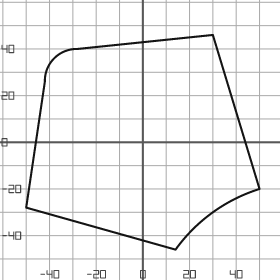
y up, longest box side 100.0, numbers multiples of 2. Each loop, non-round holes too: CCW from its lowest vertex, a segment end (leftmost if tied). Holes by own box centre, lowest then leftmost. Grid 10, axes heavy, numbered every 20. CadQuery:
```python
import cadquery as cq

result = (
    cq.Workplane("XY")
    .moveTo(14.0, -46.0)
    .threePointArc((30.0, -30.0), (50.0, -20.0))
    .lineTo(30.0, 46.0)
    .lineTo(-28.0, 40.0)
    .threePointArc((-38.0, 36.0), (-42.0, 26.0))
    .lineTo(-50.0, -28.0)
    .close()
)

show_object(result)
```